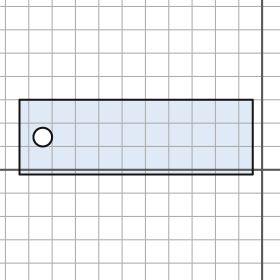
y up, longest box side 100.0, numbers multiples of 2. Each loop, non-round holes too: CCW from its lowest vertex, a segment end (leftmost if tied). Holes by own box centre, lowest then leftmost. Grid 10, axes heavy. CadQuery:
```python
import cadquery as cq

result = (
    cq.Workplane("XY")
    .moveTo(-104.0, -2.0)
    .lineTo(-4.0, -2.0)
    .lineTo(-4.0, 30.0)
    .lineTo(-104.0, 30.0)
    .close()
    .moveTo(-94.0, 14.0)
    .circle(4.0)
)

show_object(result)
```